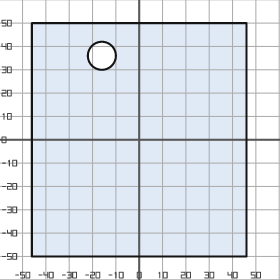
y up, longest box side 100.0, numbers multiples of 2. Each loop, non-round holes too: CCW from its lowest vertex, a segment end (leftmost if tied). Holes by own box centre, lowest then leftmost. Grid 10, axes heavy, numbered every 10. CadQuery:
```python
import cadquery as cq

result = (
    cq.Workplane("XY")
    .moveTo(-46.0, -50.0)
    .lineTo(46.0, -50.0)
    .lineTo(46.0, 50.0)
    .lineTo(-46.0, 50.0)
    .close()
    .moveTo(-16.0, 36.0)
    .circle(6.0)
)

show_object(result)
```